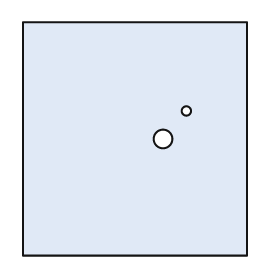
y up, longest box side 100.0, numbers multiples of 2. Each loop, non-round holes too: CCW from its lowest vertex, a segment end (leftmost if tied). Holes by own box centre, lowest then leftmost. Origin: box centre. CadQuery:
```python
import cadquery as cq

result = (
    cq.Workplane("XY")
    .moveTo(-48.0, -50.0)
    .lineTo(48.0, -50.0)
    .lineTo(48.0, 50.0)
    .lineTo(-48.0, 50.0)
    .close()
    .moveTo(12.0, 0.0)
    .circle(4.0)
    .moveTo(22.0, 12.0)
    .circle(2.0)
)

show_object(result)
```